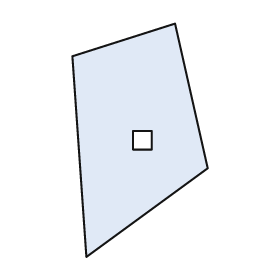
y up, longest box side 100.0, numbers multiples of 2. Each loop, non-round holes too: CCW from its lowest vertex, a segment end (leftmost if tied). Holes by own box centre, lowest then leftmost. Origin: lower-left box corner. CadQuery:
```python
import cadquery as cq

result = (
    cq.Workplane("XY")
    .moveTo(6.0, 0.0)
    .lineTo(58.0, 38.0)
    .lineTo(44.0, 100.0)
    .lineTo(0.0, 86.0)
    .close()
    .moveTo(26.0, 46.0)
    .lineTo(34.0, 46.0)
    .lineTo(34.0, 54.0)
    .lineTo(26.0, 54.0)
    .close()
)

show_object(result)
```